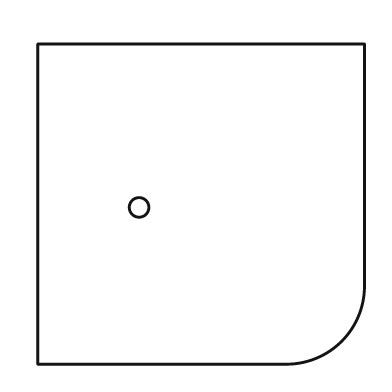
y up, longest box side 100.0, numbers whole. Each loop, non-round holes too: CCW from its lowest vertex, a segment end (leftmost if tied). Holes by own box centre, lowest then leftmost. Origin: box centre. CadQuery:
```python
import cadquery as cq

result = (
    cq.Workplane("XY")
    .moveTo(-50.0, -49.0)
    .lineTo(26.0, -49.0)
    .threePointArc((43.0, -42.0), (50.0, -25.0))
    .lineTo(50.0, 49.0)
    .lineTo(-50.0, 49.0)
    .close()
    .moveTo(-19.0, -1.0)
    .circle(3.0)
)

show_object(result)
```